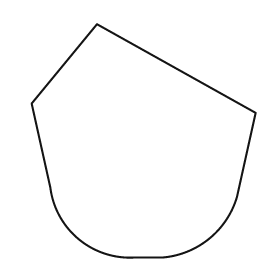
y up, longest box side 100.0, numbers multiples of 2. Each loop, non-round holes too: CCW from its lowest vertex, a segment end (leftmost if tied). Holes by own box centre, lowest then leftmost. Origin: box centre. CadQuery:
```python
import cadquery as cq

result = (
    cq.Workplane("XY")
    .moveTo(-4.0, -50.0)
    .lineTo(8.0, -50.0)
    .threePointArc((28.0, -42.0), (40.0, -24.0))
    .lineTo(48.0, 12.0)
    .lineTo(-20.0, 50.0)
    .lineTo(-48.0, 16.0)
    .lineTo(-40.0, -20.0)
    .threePointArc((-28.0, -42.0), (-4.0, -50.0))
    .close()
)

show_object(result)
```